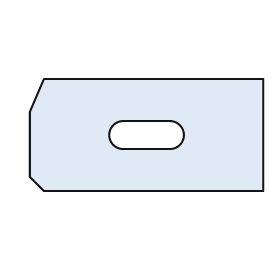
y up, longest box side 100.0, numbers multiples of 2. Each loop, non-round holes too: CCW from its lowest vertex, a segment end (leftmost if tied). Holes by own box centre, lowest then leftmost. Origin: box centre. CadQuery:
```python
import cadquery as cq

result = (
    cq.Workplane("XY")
    .moveTo(-44.0, -24.0)
    .lineTo(50.0, -24.0)
    .lineTo(50.0, 24.0)
    .lineTo(-44.0, 24.0)
    .lineTo(-50.0, 10.0)
    .lineTo(-50.0, -18.0)
    .close()
    .moveTo(-10.0, -6.0)
    .lineTo(10.0, -6.0)
    .threePointArc((16.0, 0.0), (10.0, 6.0))
    .lineTo(-10.0, 6.0)
    .threePointArc((-16.0, 0.0), (-10.0, -6.0))
    .close()
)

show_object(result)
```